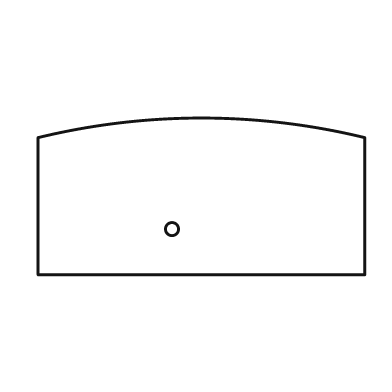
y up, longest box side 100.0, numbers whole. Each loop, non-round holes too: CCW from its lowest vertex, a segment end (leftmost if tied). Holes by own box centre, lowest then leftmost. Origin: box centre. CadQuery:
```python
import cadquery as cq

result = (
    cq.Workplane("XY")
    .moveTo(-50.0, -24.0)
    .lineTo(50.0, -24.0)
    .lineTo(50.0, 18.0)
    .threePointArc((0.0, 24.0), (-50.0, 18.0))
    .close()
    .moveTo(-9.0, -10.0)
    .circle(2.0)
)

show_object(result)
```